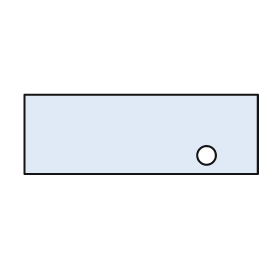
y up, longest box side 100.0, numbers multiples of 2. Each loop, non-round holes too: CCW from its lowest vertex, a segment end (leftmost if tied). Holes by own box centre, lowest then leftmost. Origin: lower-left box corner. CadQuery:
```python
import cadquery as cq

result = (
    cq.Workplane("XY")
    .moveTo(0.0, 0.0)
    .lineTo(100.0, 0.0)
    .lineTo(100.0, 34.0)
    .lineTo(0.0, 34.0)
    .close()
    .moveTo(78.0, 8.0)
    .circle(4.0)
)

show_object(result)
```